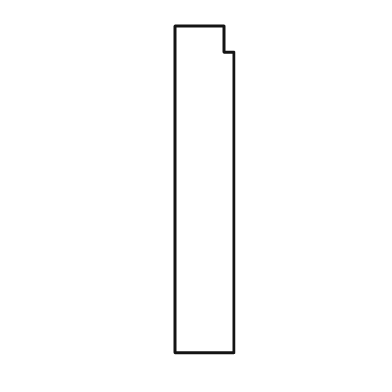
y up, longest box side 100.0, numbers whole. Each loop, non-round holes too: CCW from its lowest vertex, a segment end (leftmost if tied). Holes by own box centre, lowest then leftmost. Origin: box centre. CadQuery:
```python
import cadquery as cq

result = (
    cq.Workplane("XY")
    .moveTo(-9.0, -50.0)
    .lineTo(9.0, -50.0)
    .lineTo(9.0, 42.0)
    .lineTo(6.0, 42.0)
    .lineTo(6.0, 50.0)
    .lineTo(-9.0, 50.0)
    .close()
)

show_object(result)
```